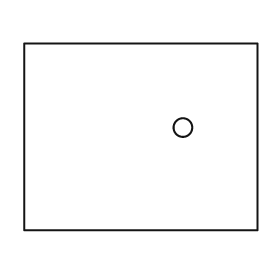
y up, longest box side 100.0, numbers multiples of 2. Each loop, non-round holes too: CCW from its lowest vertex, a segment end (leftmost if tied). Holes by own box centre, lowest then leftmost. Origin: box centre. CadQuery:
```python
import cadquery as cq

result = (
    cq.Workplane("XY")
    .moveTo(-50.0, -40.0)
    .lineTo(50.0, -40.0)
    .lineTo(50.0, 40.0)
    .lineTo(-50.0, 40.0)
    .close()
    .moveTo(18.0, 4.0)
    .circle(4.0)
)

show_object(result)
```